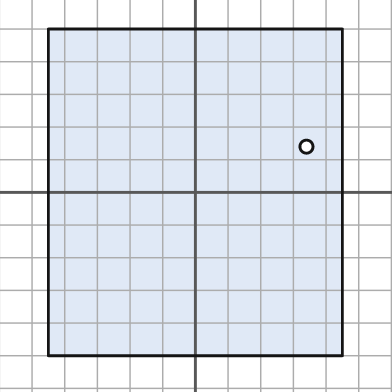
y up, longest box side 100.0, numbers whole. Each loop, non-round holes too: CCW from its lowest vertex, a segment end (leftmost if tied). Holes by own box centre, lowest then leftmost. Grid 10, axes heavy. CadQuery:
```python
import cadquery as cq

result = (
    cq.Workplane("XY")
    .moveTo(-45.0, -50.0)
    .lineTo(45.0, -50.0)
    .lineTo(45.0, 50.0)
    .lineTo(-45.0, 50.0)
    .close()
    .moveTo(34.0, 14.0)
    .circle(2.0)
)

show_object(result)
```